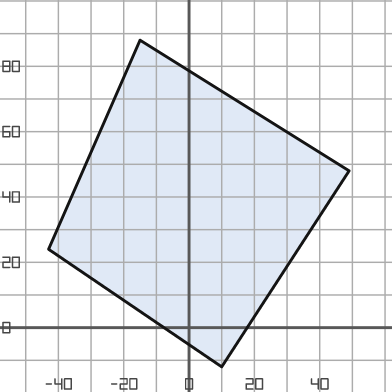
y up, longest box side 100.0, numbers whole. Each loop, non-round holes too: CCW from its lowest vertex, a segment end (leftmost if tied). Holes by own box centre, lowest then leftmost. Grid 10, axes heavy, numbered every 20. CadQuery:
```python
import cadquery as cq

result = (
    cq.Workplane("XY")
    .moveTo(10.0, -12.0)
    .lineTo(49.0, 48.0)
    .lineTo(-15.0, 88.0)
    .lineTo(-43.0, 24.0)
    .close()
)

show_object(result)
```